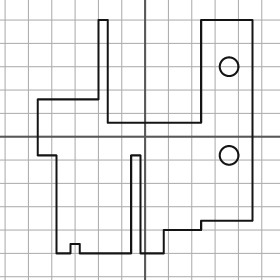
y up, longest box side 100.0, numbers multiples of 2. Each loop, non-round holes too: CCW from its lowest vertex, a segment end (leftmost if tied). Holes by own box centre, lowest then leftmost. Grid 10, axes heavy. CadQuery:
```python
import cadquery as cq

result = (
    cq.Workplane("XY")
    .moveTo(-38.0, -50.0)
    .lineTo(-32.0, -50.0)
    .lineTo(-32.0, -46.0)
    .lineTo(-28.0, -46.0)
    .lineTo(-28.0, -50.0)
    .lineTo(-6.0, -50.0)
    .lineTo(-6.0, -8.0)
    .lineTo(-2.0, -8.0)
    .lineTo(-2.0, -50.0)
    .lineTo(8.0, -50.0)
    .lineTo(8.0, -40.0)
    .lineTo(24.0, -40.0)
    .lineTo(24.0, -36.0)
    .lineTo(46.0, -36.0)
    .lineTo(46.0, 50.0)
    .lineTo(24.0, 50.0)
    .lineTo(24.0, 6.0)
    .lineTo(-16.0, 6.0)
    .lineTo(-16.0, 50.0)
    .lineTo(-20.0, 50.0)
    .lineTo(-20.0, 16.0)
    .lineTo(-46.0, 16.0)
    .lineTo(-46.0, -8.0)
    .lineTo(-38.0, -8.0)
    .close()
    .moveTo(36.0, -8.0)
    .circle(4.0)
    .moveTo(36.0, 30.0)
    .circle(4.0)
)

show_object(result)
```